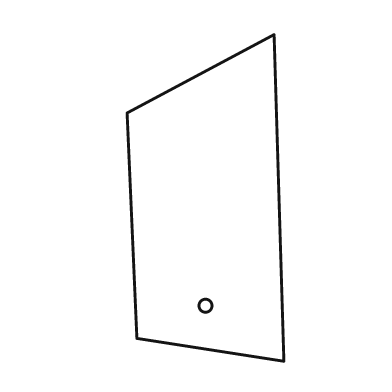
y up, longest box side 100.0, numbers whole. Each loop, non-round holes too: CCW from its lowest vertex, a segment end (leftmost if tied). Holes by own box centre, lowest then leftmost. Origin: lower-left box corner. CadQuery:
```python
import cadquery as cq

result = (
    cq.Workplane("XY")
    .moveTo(48.0, 0.0)
    .lineTo(45.0, 100.0)
    .lineTo(0.0, 76.0)
    .lineTo(3.0, 7.0)
    .close()
    .moveTo(24.0, 17.0)
    .circle(2.0)
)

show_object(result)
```